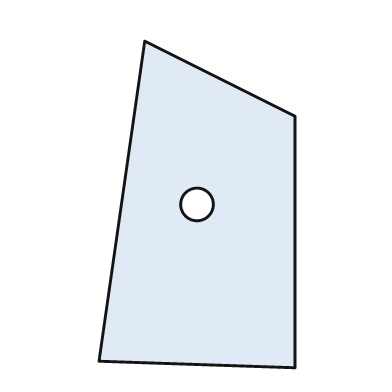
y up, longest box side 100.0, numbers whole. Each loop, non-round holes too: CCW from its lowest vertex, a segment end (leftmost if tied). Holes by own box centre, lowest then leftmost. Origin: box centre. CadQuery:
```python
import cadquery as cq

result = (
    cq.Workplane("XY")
    .moveTo(30.0, -50.0)
    .lineTo(30.0, 27.0)
    .lineTo(-16.0, 50.0)
    .lineTo(-30.0, -48.0)
    .close()
    .moveTo(0.0, 0.0)
    .circle(5.0)
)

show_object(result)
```